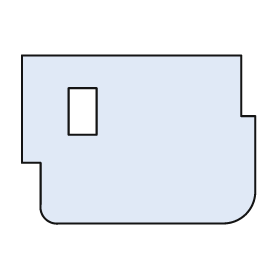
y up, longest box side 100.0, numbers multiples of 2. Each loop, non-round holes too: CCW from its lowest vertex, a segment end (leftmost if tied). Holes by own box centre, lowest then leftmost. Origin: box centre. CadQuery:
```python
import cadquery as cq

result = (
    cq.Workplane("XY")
    .moveTo(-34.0, -36.0)
    .lineTo(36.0, -36.0)
    .threePointArc((46.0, -32.0), (50.0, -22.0))
    .lineTo(50.0, 10.0)
    .lineTo(44.0, 10.0)
    .lineTo(44.0, 36.0)
    .lineTo(-50.0, 36.0)
    .lineTo(-50.0, -10.0)
    .lineTo(-42.0, -10.0)
    .lineTo(-42.0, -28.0)
    .threePointArc((-40.0, -34.0), (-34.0, -36.0))
    .close()
    .moveTo(-30.0, 2.0)
    .lineTo(-18.0, 2.0)
    .lineTo(-18.0, 22.0)
    .lineTo(-30.0, 22.0)
    .close()
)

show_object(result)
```